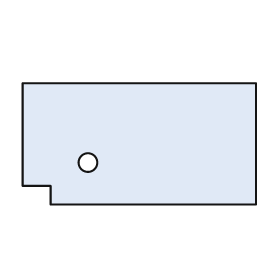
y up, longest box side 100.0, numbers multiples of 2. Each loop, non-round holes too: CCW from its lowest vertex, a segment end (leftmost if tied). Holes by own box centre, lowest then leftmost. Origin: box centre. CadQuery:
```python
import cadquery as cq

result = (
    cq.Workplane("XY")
    .moveTo(-38.0, -26.0)
    .lineTo(50.0, -26.0)
    .lineTo(50.0, 26.0)
    .lineTo(-50.0, 26.0)
    .lineTo(-50.0, -18.0)
    .lineTo(-38.0, -18.0)
    .close()
    .moveTo(-22.0, -8.0)
    .circle(4.0)
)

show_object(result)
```